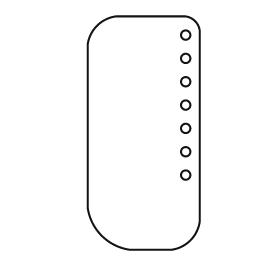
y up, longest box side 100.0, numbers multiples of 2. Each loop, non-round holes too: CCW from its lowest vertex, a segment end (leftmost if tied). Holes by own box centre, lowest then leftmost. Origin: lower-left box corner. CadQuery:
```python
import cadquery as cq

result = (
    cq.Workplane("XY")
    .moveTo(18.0, 0.0)
    .lineTo(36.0, 0.0)
    .threePointArc((44.0, 4.0), (48.0, 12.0))
    .lineTo(48.0, 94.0)
    .threePointArc((46.0, 98.0), (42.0, 100.0))
    .lineTo(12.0, 100.0)
    .threePointArc((4.0, 96.0), (0.0, 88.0))
    .lineTo(0.0, 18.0)
    .threePointArc((6.0, 6.0), (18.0, 0.0))
    .close()
    .moveTo(42.0, 32.0)
    .circle(2.0)
    .moveTo(42.0, 42.0)
    .circle(2.0)
    .moveTo(42.0, 52.0)
    .circle(2.0)
    .moveTo(42.0, 62.0)
    .circle(2.0)
    .moveTo(42.0, 72.0)
    .circle(2.0)
    .moveTo(42.0, 82.0)
    .circle(2.0)
    .moveTo(42.0, 92.0)
    .circle(2.0)
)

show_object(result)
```